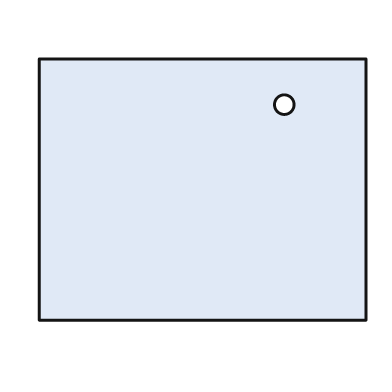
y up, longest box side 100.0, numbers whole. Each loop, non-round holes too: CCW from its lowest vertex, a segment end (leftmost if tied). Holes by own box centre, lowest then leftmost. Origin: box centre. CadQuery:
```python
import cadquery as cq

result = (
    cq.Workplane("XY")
    .moveTo(-50.0, -40.0)
    .lineTo(50.0, -40.0)
    .lineTo(50.0, 40.0)
    .lineTo(-50.0, 40.0)
    .close()
    .moveTo(25.0, 26.0)
    .circle(3.0)
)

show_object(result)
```